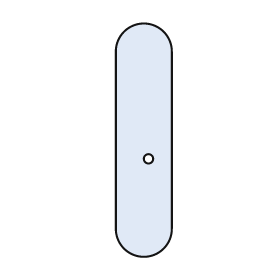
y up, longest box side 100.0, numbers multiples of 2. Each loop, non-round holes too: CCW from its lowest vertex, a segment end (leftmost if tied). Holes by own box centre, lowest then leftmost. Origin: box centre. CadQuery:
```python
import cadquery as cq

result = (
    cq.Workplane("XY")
    .moveTo(-12.0, -38.0)
    .threePointArc((0.0, -50.0), (12.0, -38.0))
    .lineTo(12.0, 38.0)
    .threePointArc((0.0, 50.0), (-12.0, 38.0))
    .close()
    .moveTo(2.0, -8.0)
    .circle(2.0)
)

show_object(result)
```